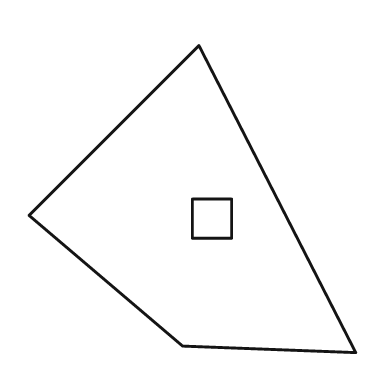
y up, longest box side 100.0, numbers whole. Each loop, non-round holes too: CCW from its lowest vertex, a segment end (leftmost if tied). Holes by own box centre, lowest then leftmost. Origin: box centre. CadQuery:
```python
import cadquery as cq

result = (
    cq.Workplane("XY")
    .moveTo(50.0, -47.0)
    .lineTo(2.0, 47.0)
    .lineTo(-50.0, -5.0)
    .lineTo(-3.0, -45.0)
    .close()
    .moveTo(0.0, -12.0)
    .lineTo(12.0, -12.0)
    .lineTo(12.0, 0.0)
    .lineTo(0.0, 0.0)
    .close()
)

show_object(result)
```